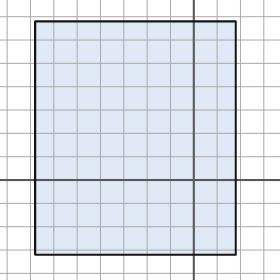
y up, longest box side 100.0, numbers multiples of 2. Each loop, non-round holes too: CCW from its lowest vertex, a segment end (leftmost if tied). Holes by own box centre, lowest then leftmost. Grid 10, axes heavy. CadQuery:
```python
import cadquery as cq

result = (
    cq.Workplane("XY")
    .moveTo(-68.0, -32.0)
    .lineTo(18.0, -32.0)
    .lineTo(18.0, 68.0)
    .lineTo(-68.0, 68.0)
    .close()
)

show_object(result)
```